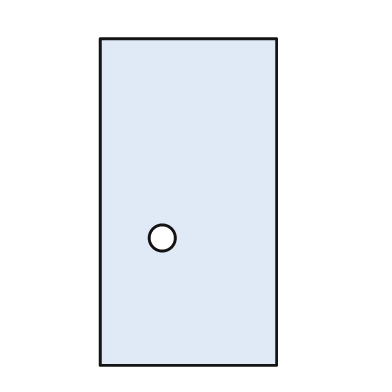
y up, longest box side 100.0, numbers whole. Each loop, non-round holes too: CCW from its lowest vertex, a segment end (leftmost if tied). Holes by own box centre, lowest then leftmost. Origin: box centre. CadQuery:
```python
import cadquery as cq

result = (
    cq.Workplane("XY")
    .moveTo(-27.0, -50.0)
    .lineTo(27.0, -50.0)
    .lineTo(27.0, 50.0)
    .lineTo(-27.0, 50.0)
    .close()
    .moveTo(-8.0, -11.0)
    .circle(4.0)
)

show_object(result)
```